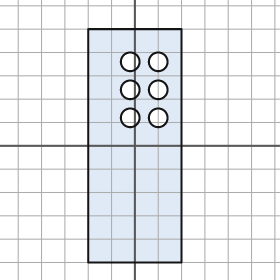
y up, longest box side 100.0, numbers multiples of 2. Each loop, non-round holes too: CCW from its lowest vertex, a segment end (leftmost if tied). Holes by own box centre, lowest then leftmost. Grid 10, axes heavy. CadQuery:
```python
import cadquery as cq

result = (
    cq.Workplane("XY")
    .moveTo(-20.0, -50.0)
    .lineTo(20.0, -50.0)
    .lineTo(20.0, 50.0)
    .lineTo(-20.0, 50.0)
    .close()
    .moveTo(-2.0, 12.0)
    .circle(4.0)
    .moveTo(10.0, 12.0)
    .circle(4.0)
    .moveTo(-2.0, 24.0)
    .circle(4.0)
    .moveTo(10.0, 24.0)
    .circle(4.0)
    .moveTo(-2.0, 36.0)
    .circle(4.0)
    .moveTo(10.0, 36.0)
    .circle(4.0)
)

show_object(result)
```